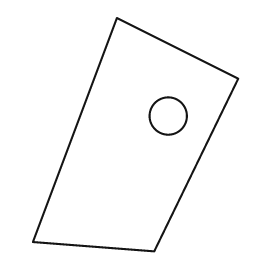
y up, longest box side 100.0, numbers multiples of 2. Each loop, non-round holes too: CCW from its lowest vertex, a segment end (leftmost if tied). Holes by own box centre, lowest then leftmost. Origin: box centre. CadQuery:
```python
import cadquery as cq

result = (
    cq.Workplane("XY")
    .moveTo(8.0, -50.0)
    .lineTo(44.0, 24.0)
    .lineTo(-8.0, 50.0)
    .lineTo(-44.0, -46.0)
    .close()
    .moveTo(14.0, 8.0)
    .circle(8.0)
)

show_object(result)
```